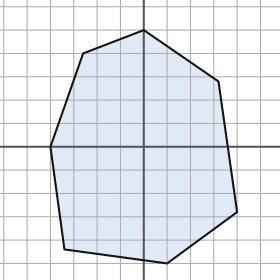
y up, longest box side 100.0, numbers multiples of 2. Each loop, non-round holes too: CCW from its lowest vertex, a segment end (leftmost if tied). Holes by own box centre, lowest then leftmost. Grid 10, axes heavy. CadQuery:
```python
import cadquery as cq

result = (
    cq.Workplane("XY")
    .moveTo(10.0, -50.0)
    .lineTo(40.0, -28.0)
    .lineTo(32.0, 28.0)
    .lineTo(0.0, 50.0)
    .lineTo(-26.0, 40.0)
    .lineTo(-40.0, 0.0)
    .lineTo(-34.0, -44.0)
    .close()
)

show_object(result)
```